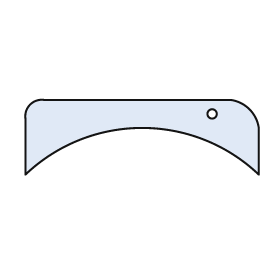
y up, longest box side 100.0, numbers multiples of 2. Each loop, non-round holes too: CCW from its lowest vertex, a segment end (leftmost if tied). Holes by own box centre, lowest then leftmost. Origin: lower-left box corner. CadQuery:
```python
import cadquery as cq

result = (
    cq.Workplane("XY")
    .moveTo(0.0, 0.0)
    .threePointArc((50.0, 20.0), (100.0, 0.0))
    .lineTo(100.0, 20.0)
    .threePointArc((96.0, 28.0), (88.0, 32.0))
    .lineTo(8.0, 32.0)
    .threePointArc((2.0, 30.0), (0.0, 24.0))
    .close()
    .moveTo(80.0, 26.0)
    .circle(2.0)
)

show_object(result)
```